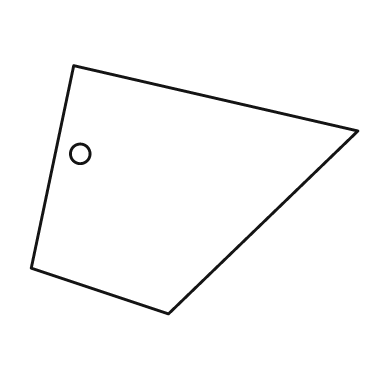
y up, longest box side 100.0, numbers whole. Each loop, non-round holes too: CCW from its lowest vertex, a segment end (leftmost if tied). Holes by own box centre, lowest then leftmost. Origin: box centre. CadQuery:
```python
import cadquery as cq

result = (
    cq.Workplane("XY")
    .moveTo(-8.0, -38.0)
    .lineTo(50.0, 18.0)
    .lineTo(-37.0, 38.0)
    .lineTo(-50.0, -24.0)
    .close()
    .moveTo(-35.0, 11.0)
    .circle(3.0)
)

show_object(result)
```